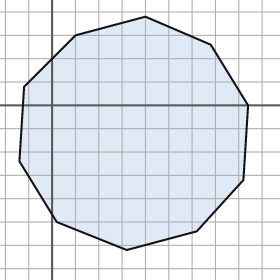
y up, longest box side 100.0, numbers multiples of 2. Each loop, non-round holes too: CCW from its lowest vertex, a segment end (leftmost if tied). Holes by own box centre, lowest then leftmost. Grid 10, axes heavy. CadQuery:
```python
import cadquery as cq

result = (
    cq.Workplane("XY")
    .moveTo(32.0, -62.0)
    .lineTo(62.0, -54.0)
    .lineTo(82.0, -32.0)
    .lineTo(84.0, 0.0)
    .lineTo(68.0, 26.0)
    .lineTo(40.0, 38.0)
    .lineTo(10.0, 30.0)
    .lineTo(-12.0, 8.0)
    .lineTo(-14.0, -24.0)
    .lineTo(2.0, -50.0)
    .close()
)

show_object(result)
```